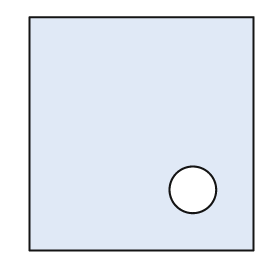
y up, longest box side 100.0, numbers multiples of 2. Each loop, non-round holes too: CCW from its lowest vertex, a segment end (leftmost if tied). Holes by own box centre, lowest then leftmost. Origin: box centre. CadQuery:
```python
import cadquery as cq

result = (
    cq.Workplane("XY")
    .moveTo(-48.0, -50.0)
    .lineTo(48.0, -50.0)
    .lineTo(48.0, 50.0)
    .lineTo(-48.0, 50.0)
    .close()
    .moveTo(22.0, -24.0)
    .circle(10.0)
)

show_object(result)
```